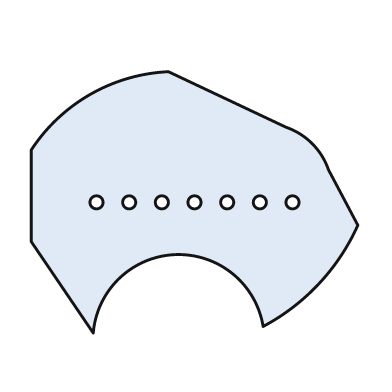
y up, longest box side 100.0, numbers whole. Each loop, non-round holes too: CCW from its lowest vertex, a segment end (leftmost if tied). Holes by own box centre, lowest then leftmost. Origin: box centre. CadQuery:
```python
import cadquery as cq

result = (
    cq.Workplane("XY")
    .moveTo(-31.0, -40.0)
    .threePointArc((-6.0, -16.0), (21.0, -38.0))
    .threePointArc((38.0, -25.0), (50.0, -7.0))
    .lineTo(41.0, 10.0)
    .threePointArc((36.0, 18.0), (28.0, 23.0))
    .lineTo(-8.0, 40.0)
    .threePointArc((-32.0, 33.0), (-50.0, 16.0))
    .lineTo(-50.0, -12.0)
    .close()
    .moveTo(-30.0, 0.0)
    .circle(2.0)
    .moveTo(-20.0, 0.0)
    .circle(2.0)
    .moveTo(-10.0, 0.0)
    .circle(2.0)
    .moveTo(0.0, 0.0)
    .circle(2.0)
    .moveTo(10.0, 0.0)
    .circle(2.0)
    .moveTo(20.0, 0.0)
    .circle(2.0)
    .moveTo(30.0, 0.0)
    .circle(2.0)
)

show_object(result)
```